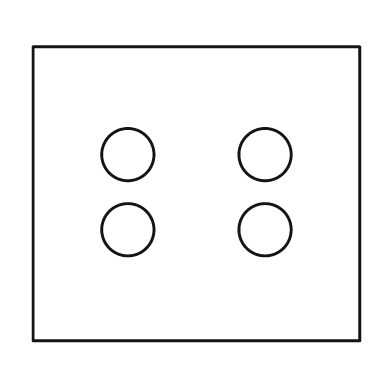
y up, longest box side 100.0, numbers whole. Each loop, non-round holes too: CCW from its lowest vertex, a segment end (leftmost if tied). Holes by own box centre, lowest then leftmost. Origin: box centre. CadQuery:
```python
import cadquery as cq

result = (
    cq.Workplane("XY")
    .moveTo(-50.0, -45.0)
    .lineTo(50.0, -45.0)
    .lineTo(50.0, 45.0)
    .lineTo(-50.0, 45.0)
    .close()
    .moveTo(-21.0, -11.0)
    .circle(8.0)
    .moveTo(21.0, -11.0)
    .circle(8.0)
    .moveTo(-21.0, 12.0)
    .circle(8.0)
    .moveTo(21.0, 12.0)
    .circle(8.0)
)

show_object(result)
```